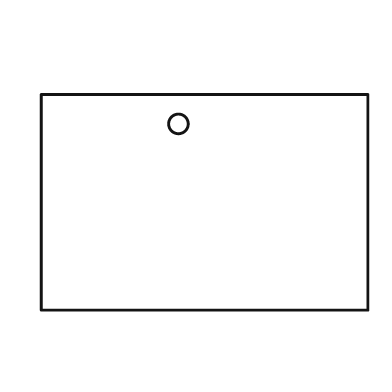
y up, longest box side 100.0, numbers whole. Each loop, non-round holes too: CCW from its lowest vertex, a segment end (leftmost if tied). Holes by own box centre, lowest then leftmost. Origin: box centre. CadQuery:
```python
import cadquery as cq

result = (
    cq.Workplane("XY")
    .moveTo(-50.0, -33.0)
    .lineTo(50.0, -33.0)
    .lineTo(50.0, 33.0)
    .lineTo(-50.0, 33.0)
    .close()
    .moveTo(-8.0, 24.0)
    .circle(3.0)
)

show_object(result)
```